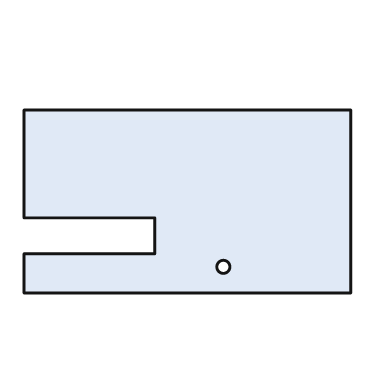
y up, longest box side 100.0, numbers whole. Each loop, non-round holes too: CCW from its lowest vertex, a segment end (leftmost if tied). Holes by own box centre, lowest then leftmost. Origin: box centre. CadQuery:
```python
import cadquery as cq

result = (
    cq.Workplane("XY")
    .moveTo(-50.0, -28.0)
    .lineTo(50.0, -28.0)
    .lineTo(50.0, 28.0)
    .lineTo(-50.0, 28.0)
    .lineTo(-50.0, -5.0)
    .lineTo(-10.0, -5.0)
    .lineTo(-10.0, -16.0)
    .lineTo(-50.0, -16.0)
    .close()
    .moveTo(11.0, -20.0)
    .circle(2.0)
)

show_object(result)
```